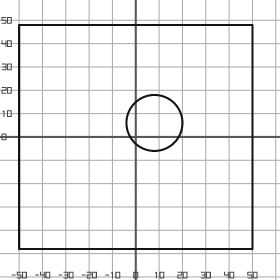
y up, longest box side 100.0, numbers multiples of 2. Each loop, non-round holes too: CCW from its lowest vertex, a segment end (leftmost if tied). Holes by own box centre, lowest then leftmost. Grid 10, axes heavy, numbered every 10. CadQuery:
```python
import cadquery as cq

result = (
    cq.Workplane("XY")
    .moveTo(-50.0, -48.0)
    .lineTo(50.0, -48.0)
    .lineTo(50.0, 48.0)
    .lineTo(-50.0, 48.0)
    .close()
    .moveTo(8.0, 6.0)
    .circle(12.0)
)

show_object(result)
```